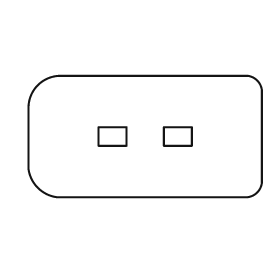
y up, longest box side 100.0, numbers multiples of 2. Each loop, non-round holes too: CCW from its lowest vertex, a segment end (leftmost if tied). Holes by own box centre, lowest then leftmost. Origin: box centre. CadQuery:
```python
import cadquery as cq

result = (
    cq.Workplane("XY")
    .moveTo(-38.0, -26.0)
    .lineTo(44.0, -26.0)
    .threePointArc((48.0, -24.0), (50.0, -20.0))
    .lineTo(50.0, 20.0)
    .threePointArc((48.0, 24.0), (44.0, 26.0))
    .lineTo(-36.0, 26.0)
    .threePointArc((-46.0, 22.0), (-50.0, 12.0))
    .lineTo(-50.0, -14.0)
    .threePointArc((-46.0, -22.0), (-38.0, -26.0))
    .close()
    .moveTo(-20.0, -4.0)
    .lineTo(-8.0, -4.0)
    .lineTo(-8.0, 4.0)
    .lineTo(-20.0, 4.0)
    .close()
    .moveTo(8.0, -4.0)
    .lineTo(20.0, -4.0)
    .lineTo(20.0, 4.0)
    .lineTo(8.0, 4.0)
    .close()
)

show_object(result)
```